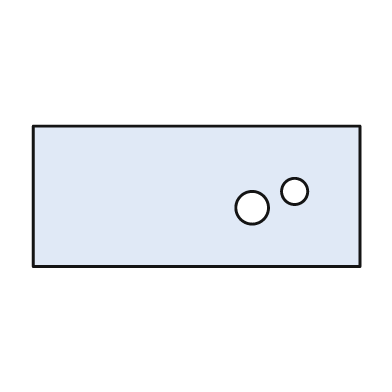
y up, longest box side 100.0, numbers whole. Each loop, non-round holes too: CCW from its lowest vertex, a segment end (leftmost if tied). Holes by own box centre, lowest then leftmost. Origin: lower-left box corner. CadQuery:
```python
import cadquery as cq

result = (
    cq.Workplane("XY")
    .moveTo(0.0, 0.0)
    .lineTo(100.0, 0.0)
    .lineTo(100.0, 43.0)
    .lineTo(0.0, 43.0)
    .close()
    .moveTo(67.0, 18.0)
    .circle(5.0)
    .moveTo(80.0, 23.0)
    .circle(4.0)
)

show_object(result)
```